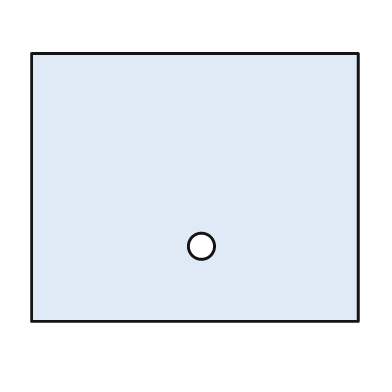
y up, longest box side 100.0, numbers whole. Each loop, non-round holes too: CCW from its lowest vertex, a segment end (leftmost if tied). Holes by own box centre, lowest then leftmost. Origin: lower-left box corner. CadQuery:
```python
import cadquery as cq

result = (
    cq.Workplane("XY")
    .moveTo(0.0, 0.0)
    .lineTo(100.0, 0.0)
    .lineTo(100.0, 82.0)
    .lineTo(0.0, 82.0)
    .close()
    .moveTo(52.0, 23.0)
    .circle(4.0)
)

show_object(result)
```